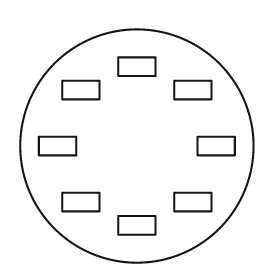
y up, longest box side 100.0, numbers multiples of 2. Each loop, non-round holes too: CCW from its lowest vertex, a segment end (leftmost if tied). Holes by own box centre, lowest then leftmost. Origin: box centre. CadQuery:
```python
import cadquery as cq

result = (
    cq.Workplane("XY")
    .moveTo(0.0, 0.0)
    .circle(50.0)
    .moveTo(-8.0, -38.0)
    .lineTo(8.0, -38.0)
    .lineTo(8.0, -30.0)
    .lineTo(-8.0, -30.0)
    .close()
    .moveTo(-32.0, -28.0)
    .lineTo(-16.0, -28.0)
    .lineTo(-16.0, -20.0)
    .lineTo(-32.0, -20.0)
    .close()
    .moveTo(16.0, -28.0)
    .lineTo(32.0, -28.0)
    .lineTo(32.0, -20.0)
    .lineTo(16.0, -20.0)
    .close()
    .moveTo(-42.0, -4.0)
    .lineTo(-26.0, -4.0)
    .lineTo(-26.0, 4.0)
    .lineTo(-42.0, 4.0)
    .close()
    .moveTo(26.0, -4.0)
    .lineTo(42.0, -4.0)
    .lineTo(42.0, 4.0)
    .lineTo(26.0, 4.0)
    .close()
    .moveTo(-32.0, 20.0)
    .lineTo(-16.0, 20.0)
    .lineTo(-16.0, 28.0)
    .lineTo(-32.0, 28.0)
    .close()
    .moveTo(16.0, 20.0)
    .lineTo(32.0, 20.0)
    .lineTo(32.0, 28.0)
    .lineTo(16.0, 28.0)
    .close()
    .moveTo(-8.0, 30.0)
    .lineTo(8.0, 30.0)
    .lineTo(8.0, 38.0)
    .lineTo(-8.0, 38.0)
    .close()
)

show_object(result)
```